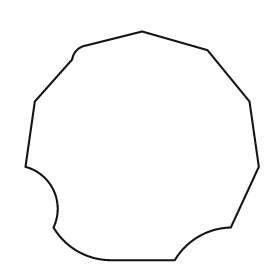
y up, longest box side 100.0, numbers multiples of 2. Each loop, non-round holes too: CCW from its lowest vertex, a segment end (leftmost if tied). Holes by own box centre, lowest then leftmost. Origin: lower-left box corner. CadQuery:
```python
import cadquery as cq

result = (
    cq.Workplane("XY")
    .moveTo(36.0, 0.0)
    .lineTo(64.0, 0.0)
    .threePointArc((74.0, 10.0), (88.0, 14.0))
    .lineTo(100.0, 40.0)
    .lineTo(96.0, 68.0)
    .lineTo(78.0, 90.0)
    .lineTo(50.0, 98.0)
    .lineTo(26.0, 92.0)
    .threePointArc((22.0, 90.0), (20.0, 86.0))
    .lineTo(4.0, 68.0)
    .lineTo(0.0, 40.0)
    .threePointArc((12.0, 30.0), (12.0, 14.0))
    .threePointArc((22.0, 4.0), (36.0, 0.0))
    .close()
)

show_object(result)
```